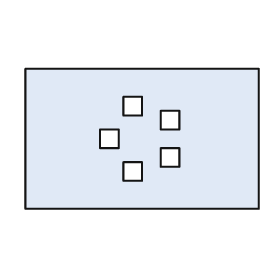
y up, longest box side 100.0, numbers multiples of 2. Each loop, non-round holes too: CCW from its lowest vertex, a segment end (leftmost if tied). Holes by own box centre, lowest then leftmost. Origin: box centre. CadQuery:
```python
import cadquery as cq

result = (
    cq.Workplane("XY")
    .moveTo(-50.0, -30.0)
    .lineTo(50.0, -30.0)
    .lineTo(50.0, 30.0)
    .lineTo(-50.0, 30.0)
    .close()
    .moveTo(-8.0, -18.0)
    .lineTo(0.0, -18.0)
    .lineTo(0.0, -10.0)
    .lineTo(-8.0, -10.0)
    .close()
    .moveTo(8.0, -12.0)
    .lineTo(16.0, -12.0)
    .lineTo(16.0, -4.0)
    .lineTo(8.0, -4.0)
    .close()
    .moveTo(-18.0, -4.0)
    .lineTo(-10.0, -4.0)
    .lineTo(-10.0, 4.0)
    .lineTo(-18.0, 4.0)
    .close()
    .moveTo(8.0, 4.0)
    .lineTo(16.0, 4.0)
    .lineTo(16.0, 12.0)
    .lineTo(8.0, 12.0)
    .close()
    .moveTo(-8.0, 10.0)
    .lineTo(0.0, 10.0)
    .lineTo(0.0, 18.0)
    .lineTo(-8.0, 18.0)
    .close()
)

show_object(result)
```